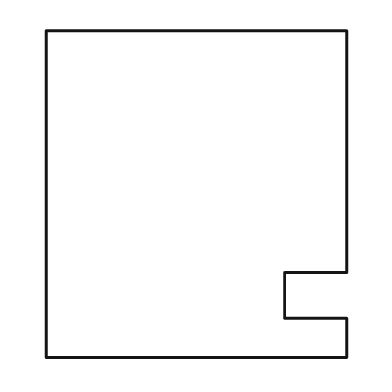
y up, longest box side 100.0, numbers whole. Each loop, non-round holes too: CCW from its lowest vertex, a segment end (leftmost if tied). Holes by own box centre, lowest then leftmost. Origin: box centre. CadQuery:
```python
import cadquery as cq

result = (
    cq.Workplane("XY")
    .moveTo(-46.0, -50.0)
    .lineTo(46.0, -50.0)
    .lineTo(46.0, -38.0)
    .lineTo(27.0, -38.0)
    .lineTo(27.0, -24.0)
    .lineTo(46.0, -24.0)
    .lineTo(46.0, 50.0)
    .lineTo(-46.0, 50.0)
    .close()
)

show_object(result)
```